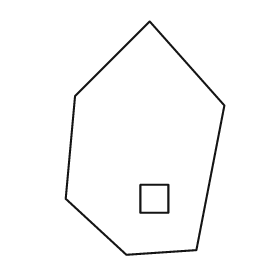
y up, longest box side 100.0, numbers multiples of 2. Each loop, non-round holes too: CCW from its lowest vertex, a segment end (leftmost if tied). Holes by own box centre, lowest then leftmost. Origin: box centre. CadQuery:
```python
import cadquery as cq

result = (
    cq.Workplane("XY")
    .moveTo(-8.0, -50.0)
    .lineTo(22.0, -48.0)
    .lineTo(34.0, 14.0)
    .lineTo(2.0, 50.0)
    .lineTo(-30.0, 18.0)
    .lineTo(-34.0, -26.0)
    .close()
    .moveTo(-2.0, -32.0)
    .lineTo(10.0, -32.0)
    .lineTo(10.0, -20.0)
    .lineTo(-2.0, -20.0)
    .close()
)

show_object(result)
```